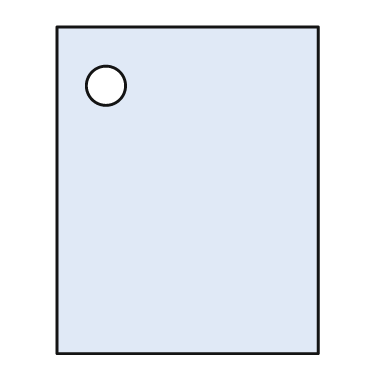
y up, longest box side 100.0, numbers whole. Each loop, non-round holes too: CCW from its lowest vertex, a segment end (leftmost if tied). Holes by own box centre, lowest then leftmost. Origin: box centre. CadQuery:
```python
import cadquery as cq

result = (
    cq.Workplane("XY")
    .moveTo(-40.0, -50.0)
    .lineTo(40.0, -50.0)
    .lineTo(40.0, 50.0)
    .lineTo(-40.0, 50.0)
    .close()
    .moveTo(-25.0, 32.0)
    .circle(6.0)
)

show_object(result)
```